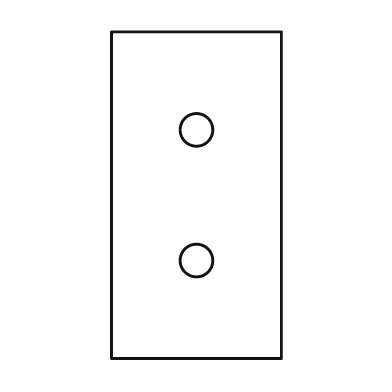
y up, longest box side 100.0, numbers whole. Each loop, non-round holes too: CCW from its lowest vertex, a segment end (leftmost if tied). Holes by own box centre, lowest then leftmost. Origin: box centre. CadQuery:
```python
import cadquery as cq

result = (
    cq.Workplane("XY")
    .moveTo(-26.0, -50.0)
    .lineTo(26.0, -50.0)
    .lineTo(26.0, 50.0)
    .lineTo(-26.0, 50.0)
    .close()
    .moveTo(0.0, -20.0)
    .circle(5.0)
    .moveTo(0.0, 20.0)
    .circle(5.0)
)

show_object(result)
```